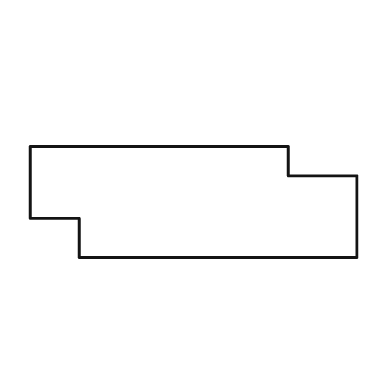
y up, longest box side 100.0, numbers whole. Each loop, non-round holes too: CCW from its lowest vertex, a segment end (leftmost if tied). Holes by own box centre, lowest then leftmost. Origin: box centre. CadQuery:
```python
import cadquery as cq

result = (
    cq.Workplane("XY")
    .moveTo(-35.0, -17.0)
    .lineTo(50.0, -17.0)
    .lineTo(50.0, 8.0)
    .lineTo(29.0, 8.0)
    .lineTo(29.0, 17.0)
    .lineTo(-50.0, 17.0)
    .lineTo(-50.0, -5.0)
    .lineTo(-35.0, -5.0)
    .close()
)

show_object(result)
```